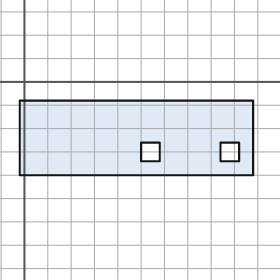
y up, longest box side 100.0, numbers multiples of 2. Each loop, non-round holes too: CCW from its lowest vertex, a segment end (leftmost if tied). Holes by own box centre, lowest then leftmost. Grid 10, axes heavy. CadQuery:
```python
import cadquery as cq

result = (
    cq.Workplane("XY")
    .moveTo(-2.0, -40.0)
    .lineTo(98.0, -40.0)
    .lineTo(98.0, -8.0)
    .lineTo(-2.0, -8.0)
    .close()
    .moveTo(50.0, -34.0)
    .lineTo(58.0, -34.0)
    .lineTo(58.0, -26.0)
    .lineTo(50.0, -26.0)
    .close()
    .moveTo(84.0, -34.0)
    .lineTo(92.0, -34.0)
    .lineTo(92.0, -26.0)
    .lineTo(84.0, -26.0)
    .close()
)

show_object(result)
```